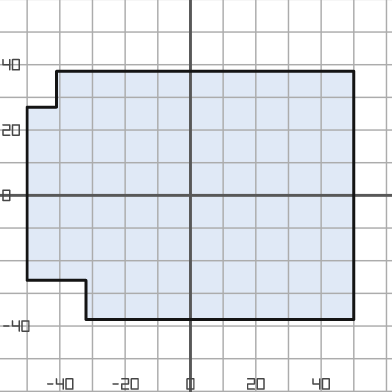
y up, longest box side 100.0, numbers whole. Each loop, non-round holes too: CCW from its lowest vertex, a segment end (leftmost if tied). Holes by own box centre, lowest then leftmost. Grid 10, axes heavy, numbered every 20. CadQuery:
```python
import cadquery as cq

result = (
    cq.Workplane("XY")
    .moveTo(-32.0, -38.0)
    .lineTo(50.0, -38.0)
    .lineTo(50.0, 38.0)
    .lineTo(-41.0, 38.0)
    .lineTo(-41.0, 27.0)
    .lineTo(-50.0, 27.0)
    .lineTo(-50.0, -26.0)
    .lineTo(-32.0, -26.0)
    .close()
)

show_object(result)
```